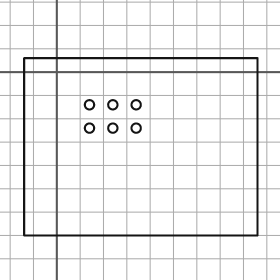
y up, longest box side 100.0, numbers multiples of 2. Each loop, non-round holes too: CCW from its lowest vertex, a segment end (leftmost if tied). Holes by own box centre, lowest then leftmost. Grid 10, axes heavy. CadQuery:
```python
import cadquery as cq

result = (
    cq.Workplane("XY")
    .moveTo(-14.0, -70.0)
    .lineTo(86.0, -70.0)
    .lineTo(86.0, 6.0)
    .lineTo(-14.0, 6.0)
    .close()
    .moveTo(14.0, -24.0)
    .circle(2.0)
    .moveTo(24.0, -24.0)
    .circle(2.0)
    .moveTo(34.0, -24.0)
    .circle(2.0)
    .moveTo(14.0, -14.0)
    .circle(2.0)
    .moveTo(24.0, -14.0)
    .circle(2.0)
    .moveTo(34.0, -14.0)
    .circle(2.0)
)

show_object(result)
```